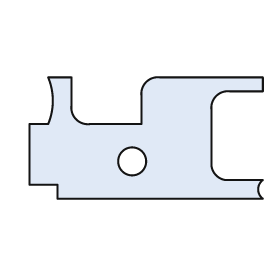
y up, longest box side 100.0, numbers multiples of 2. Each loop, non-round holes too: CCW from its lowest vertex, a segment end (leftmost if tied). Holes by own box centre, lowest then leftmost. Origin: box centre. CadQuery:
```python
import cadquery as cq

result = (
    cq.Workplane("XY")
    .moveTo(-38.0, -26.0)
    .lineTo(50.0, -26.0)
    .threePointArc((48.0, -22.0), (50.0, -18.0))
    .lineTo(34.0, -18.0)
    .threePointArc((30.0, -16.0), (28.0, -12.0))
    .lineTo(28.0, 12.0)
    .threePointArc((30.0, 18.0), (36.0, 20.0))
    .lineTo(50.0, 20.0)
    .lineTo(50.0, 26.0)
    .lineTo(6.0, 26.0)
    .threePointArc((0.0, 24.0), (-2.0, 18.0))
    .lineTo(-2.0, 6.0)
    .lineTo(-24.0, 6.0)
    .threePointArc((-30.0, 8.0), (-32.0, 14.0))
    .lineTo(-32.0, 26.0)
    .lineTo(-42.0, 26.0)
    .threePointArc((-40.0, 16.0), (-42.0, 6.0))
    .lineTo(-50.0, 6.0)
    .lineTo(-50.0, -20.0)
    .lineTo(-38.0, -20.0)
    .close()
    .moveTo(-6.0, -10.0)
    .circle(6.0)
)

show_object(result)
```